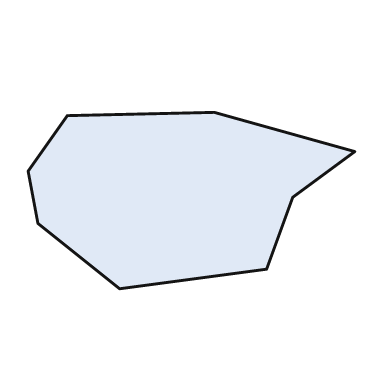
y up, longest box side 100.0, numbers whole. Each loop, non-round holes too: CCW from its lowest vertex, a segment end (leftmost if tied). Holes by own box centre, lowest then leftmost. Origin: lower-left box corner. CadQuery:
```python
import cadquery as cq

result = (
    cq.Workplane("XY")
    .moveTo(28.0, 0.0)
    .lineTo(73.0, 6.0)
    .lineTo(81.0, 28.0)
    .lineTo(100.0, 42.0)
    .lineTo(57.0, 54.0)
    .lineTo(12.0, 53.0)
    .lineTo(0.0, 36.0)
    .lineTo(3.0, 20.0)
    .close()
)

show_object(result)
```